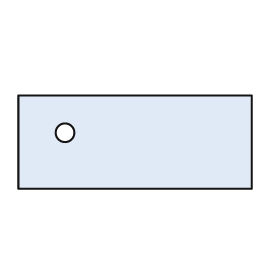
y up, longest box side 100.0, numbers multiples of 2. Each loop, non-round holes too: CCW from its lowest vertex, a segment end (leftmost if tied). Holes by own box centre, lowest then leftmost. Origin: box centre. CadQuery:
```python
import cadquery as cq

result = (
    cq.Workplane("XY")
    .moveTo(-50.0, -20.0)
    .lineTo(50.0, -20.0)
    .lineTo(50.0, 20.0)
    .lineTo(-50.0, 20.0)
    .close()
    .moveTo(-30.0, 4.0)
    .circle(4.0)
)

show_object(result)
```